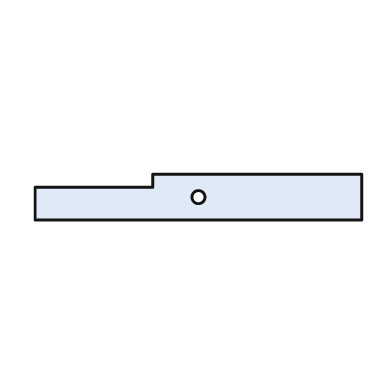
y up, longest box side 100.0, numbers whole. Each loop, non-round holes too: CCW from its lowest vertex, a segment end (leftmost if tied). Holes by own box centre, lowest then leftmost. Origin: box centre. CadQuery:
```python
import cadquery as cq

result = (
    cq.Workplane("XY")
    .moveTo(-50.0, -7.0)
    .lineTo(50.0, -7.0)
    .lineTo(50.0, 7.0)
    .lineTo(-14.0, 7.0)
    .lineTo(-14.0, 3.0)
    .lineTo(-50.0, 3.0)
    .close()
    .moveTo(0.0, 0.0)
    .circle(2.0)
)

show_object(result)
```